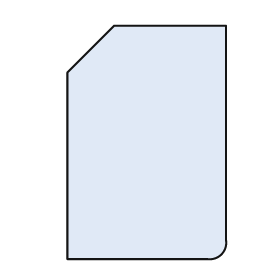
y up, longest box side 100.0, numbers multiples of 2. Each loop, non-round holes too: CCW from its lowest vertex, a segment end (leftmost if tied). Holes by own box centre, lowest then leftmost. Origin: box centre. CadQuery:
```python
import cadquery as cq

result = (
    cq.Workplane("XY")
    .moveTo(-34.0, -50.0)
    .lineTo(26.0, -50.0)
    .threePointArc((32.0, -48.0), (34.0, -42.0))
    .lineTo(34.0, 50.0)
    .lineTo(-14.0, 50.0)
    .lineTo(-34.0, 30.0)
    .close()
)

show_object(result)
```